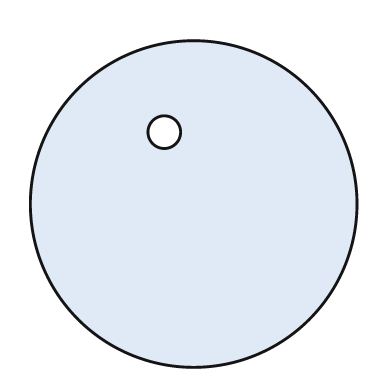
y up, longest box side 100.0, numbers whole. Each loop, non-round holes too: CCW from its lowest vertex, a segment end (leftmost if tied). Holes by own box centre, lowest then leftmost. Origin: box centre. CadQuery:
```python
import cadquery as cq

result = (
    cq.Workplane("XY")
    .moveTo(0.0, 0.0)
    .circle(50.0)
    .moveTo(-9.0, 22.0)
    .circle(5.0)
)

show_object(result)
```